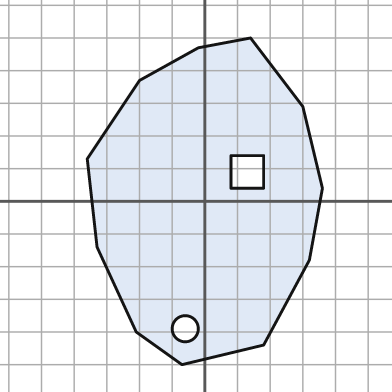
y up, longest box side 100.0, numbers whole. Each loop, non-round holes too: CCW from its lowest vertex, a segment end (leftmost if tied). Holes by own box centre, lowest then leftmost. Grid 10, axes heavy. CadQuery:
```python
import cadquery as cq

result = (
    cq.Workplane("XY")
    .moveTo(-7.0, -50.0)
    .lineTo(18.0, -44.0)
    .lineTo(32.0, -18.0)
    .lineTo(36.0, 4.0)
    .lineTo(30.0, 29.0)
    .lineTo(14.0, 50.0)
    .lineTo(-2.0, 47.0)
    .lineTo(-20.0, 37.0)
    .lineTo(-36.0, 13.0)
    .lineTo(-33.0, -14.0)
    .lineTo(-21.0, -40.0)
    .close()
    .moveTo(-6.0, -39.0)
    .circle(4.0)
    .moveTo(8.0, 4.0)
    .lineTo(18.0, 4.0)
    .lineTo(18.0, 14.0)
    .lineTo(8.0, 14.0)
    .close()
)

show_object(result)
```